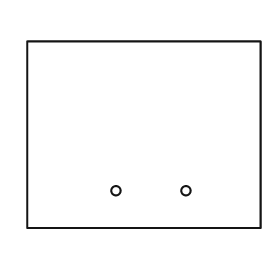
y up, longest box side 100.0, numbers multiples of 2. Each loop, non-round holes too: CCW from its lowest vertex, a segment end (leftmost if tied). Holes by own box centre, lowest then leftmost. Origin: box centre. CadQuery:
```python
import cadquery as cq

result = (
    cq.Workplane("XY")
    .moveTo(-50.0, -40.0)
    .lineTo(50.0, -40.0)
    .lineTo(50.0, 40.0)
    .lineTo(-50.0, 40.0)
    .close()
    .moveTo(-12.0, -24.0)
    .circle(2.0)
    .moveTo(18.0, -24.0)
    .circle(2.0)
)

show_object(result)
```